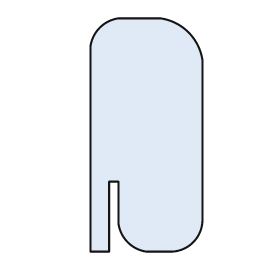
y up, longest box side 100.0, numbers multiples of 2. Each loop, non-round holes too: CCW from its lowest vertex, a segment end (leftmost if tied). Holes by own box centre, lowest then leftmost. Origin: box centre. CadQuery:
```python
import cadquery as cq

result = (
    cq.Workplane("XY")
    .moveTo(-24.0, -50.0)
    .lineTo(-16.0, -50.0)
    .lineTo(-16.0, -20.0)
    .lineTo(-12.0, -20.0)
    .lineTo(-12.0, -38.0)
    .threePointArc((-8.0, -46.0), (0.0, -50.0))
    .lineTo(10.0, -50.0)
    .threePointArc((20.0, -46.0), (24.0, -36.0))
    .lineTo(24.0, 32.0)
    .threePointArc((18.0, 44.0), (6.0, 50.0))
    .lineTo(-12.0, 50.0)
    .threePointArc((-20.0, 46.0), (-24.0, 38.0))
    .close()
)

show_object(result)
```